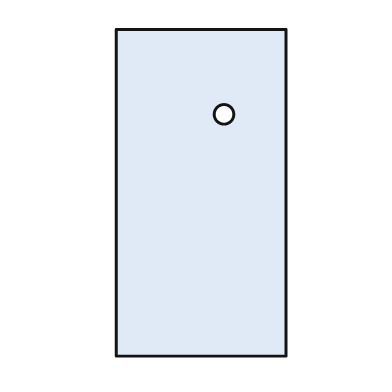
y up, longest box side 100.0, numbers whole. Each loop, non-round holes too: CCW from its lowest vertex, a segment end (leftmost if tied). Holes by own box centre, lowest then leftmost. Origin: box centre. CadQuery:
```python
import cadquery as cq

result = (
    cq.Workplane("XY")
    .moveTo(-26.0, -50.0)
    .lineTo(26.0, -50.0)
    .lineTo(26.0, 50.0)
    .lineTo(-26.0, 50.0)
    .close()
    .moveTo(7.0, 24.0)
    .circle(3.0)
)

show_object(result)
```